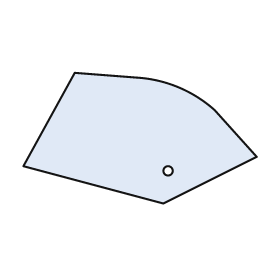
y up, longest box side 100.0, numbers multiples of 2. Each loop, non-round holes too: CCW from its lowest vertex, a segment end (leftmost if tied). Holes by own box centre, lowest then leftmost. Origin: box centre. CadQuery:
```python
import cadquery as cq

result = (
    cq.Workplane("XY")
    .moveTo(10.0, -28.0)
    .lineTo(50.0, -8.0)
    .lineTo(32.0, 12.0)
    .threePointArc((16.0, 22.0), (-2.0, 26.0))
    .lineTo(-28.0, 28.0)
    .lineTo(-50.0, -12.0)
    .close()
    .moveTo(12.0, -14.0)
    .circle(2.0)
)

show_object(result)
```